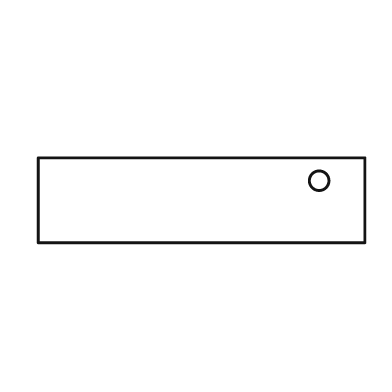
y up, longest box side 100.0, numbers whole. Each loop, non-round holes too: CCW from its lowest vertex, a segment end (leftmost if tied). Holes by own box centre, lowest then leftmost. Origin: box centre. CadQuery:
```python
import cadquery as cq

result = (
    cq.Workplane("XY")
    .moveTo(-50.0, -13.0)
    .lineTo(50.0, -13.0)
    .lineTo(50.0, 13.0)
    .lineTo(-50.0, 13.0)
    .close()
    .moveTo(36.0, 6.0)
    .circle(3.0)
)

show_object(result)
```